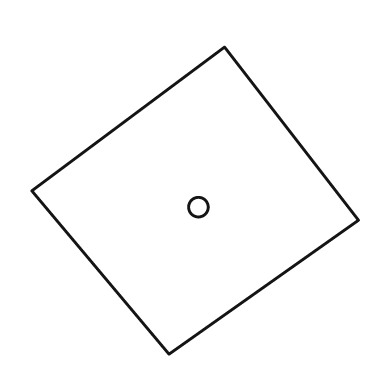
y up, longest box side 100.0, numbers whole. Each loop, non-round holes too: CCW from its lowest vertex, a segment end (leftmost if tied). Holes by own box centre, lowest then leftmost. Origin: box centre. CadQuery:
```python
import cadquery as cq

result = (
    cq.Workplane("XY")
    .moveTo(-8.0, -47.0)
    .lineTo(50.0, -6.0)
    .lineTo(9.0, 47.0)
    .lineTo(-50.0, 3.0)
    .close()
    .moveTo(1.0, -2.0)
    .circle(3.0)
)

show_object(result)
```